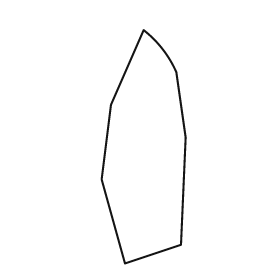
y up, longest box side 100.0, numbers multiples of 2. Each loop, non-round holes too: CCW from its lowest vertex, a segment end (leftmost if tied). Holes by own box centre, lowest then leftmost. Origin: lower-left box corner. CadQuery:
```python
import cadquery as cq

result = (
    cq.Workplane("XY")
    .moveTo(10.0, 0.0)
    .lineTo(34.0, 8.0)
    .lineTo(36.0, 54.0)
    .lineTo(32.0, 82.0)
    .threePointArc((26.0, 92.0), (18.0, 100.0))
    .lineTo(4.0, 68.0)
    .lineTo(0.0, 36.0)
    .close()
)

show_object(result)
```